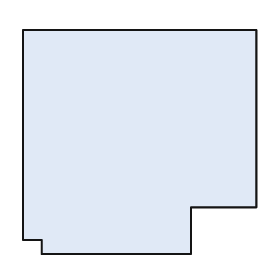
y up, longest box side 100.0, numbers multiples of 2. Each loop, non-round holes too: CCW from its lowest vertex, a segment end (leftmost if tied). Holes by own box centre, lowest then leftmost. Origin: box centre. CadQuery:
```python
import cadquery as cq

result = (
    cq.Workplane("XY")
    .moveTo(-42.0, -48.0)
    .lineTo(22.0, -48.0)
    .lineTo(22.0, -28.0)
    .lineTo(50.0, -28.0)
    .lineTo(50.0, 48.0)
    .lineTo(-50.0, 48.0)
    .lineTo(-50.0, -42.0)
    .lineTo(-42.0, -42.0)
    .close()
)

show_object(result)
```